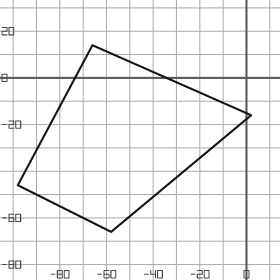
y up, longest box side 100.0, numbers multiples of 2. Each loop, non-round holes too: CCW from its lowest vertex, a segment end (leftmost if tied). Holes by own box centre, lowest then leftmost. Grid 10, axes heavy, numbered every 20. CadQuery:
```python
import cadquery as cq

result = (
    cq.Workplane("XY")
    .moveTo(-58.0, -66.0)
    .lineTo(2.0, -16.0)
    .lineTo(-66.0, 14.0)
    .lineTo(-98.0, -46.0)
    .close()
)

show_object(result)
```